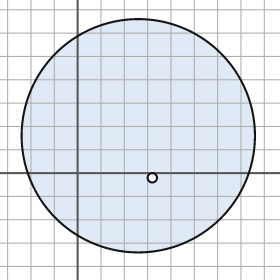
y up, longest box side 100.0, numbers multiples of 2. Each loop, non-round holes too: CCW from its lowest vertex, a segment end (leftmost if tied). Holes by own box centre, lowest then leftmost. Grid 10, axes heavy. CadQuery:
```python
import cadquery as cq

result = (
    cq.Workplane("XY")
    .moveTo(26.0, 16.0)
    .circle(50.0)
    .moveTo(32.0, -2.0)
    .circle(2.0)
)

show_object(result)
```